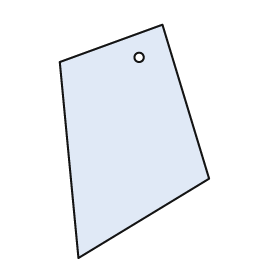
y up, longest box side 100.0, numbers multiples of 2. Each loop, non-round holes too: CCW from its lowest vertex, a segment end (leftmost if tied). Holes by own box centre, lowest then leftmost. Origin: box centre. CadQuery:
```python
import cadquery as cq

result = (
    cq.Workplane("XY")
    .moveTo(-24.0, -50.0)
    .lineTo(32.0, -16.0)
    .lineTo(12.0, 50.0)
    .lineTo(-32.0, 34.0)
    .close()
    .moveTo(2.0, 36.0)
    .circle(2.0)
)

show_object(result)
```